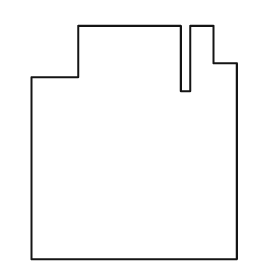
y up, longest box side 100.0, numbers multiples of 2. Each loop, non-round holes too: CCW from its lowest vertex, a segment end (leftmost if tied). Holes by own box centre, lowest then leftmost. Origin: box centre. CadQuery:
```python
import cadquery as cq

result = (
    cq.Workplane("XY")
    .moveTo(-44.0, -50.0)
    .lineTo(44.0, -50.0)
    .lineTo(44.0, 34.0)
    .lineTo(34.0, 34.0)
    .lineTo(34.0, 50.0)
    .lineTo(24.0, 50.0)
    .lineTo(24.0, 22.0)
    .lineTo(20.0, 22.0)
    .lineTo(20.0, 50.0)
    .lineTo(-24.0, 50.0)
    .lineTo(-24.0, 28.0)
    .lineTo(-44.0, 28.0)
    .close()
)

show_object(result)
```